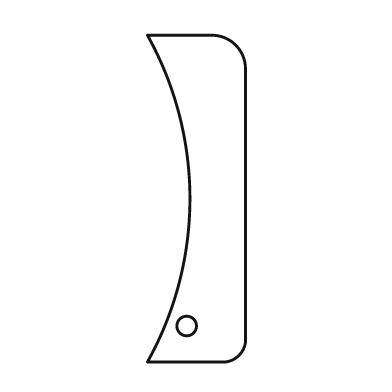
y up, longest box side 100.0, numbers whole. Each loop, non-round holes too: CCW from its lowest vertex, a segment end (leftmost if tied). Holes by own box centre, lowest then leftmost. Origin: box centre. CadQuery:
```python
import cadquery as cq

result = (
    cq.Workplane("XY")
    .moveTo(-15.0, -50.0)
    .lineTo(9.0, -50.0)
    .threePointArc((13.0, -48.0), (15.0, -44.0))
    .lineTo(15.0, 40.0)
    .threePointArc((12.0, 47.0), (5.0, 50.0))
    .lineTo(-15.0, 50.0)
    .threePointArc((-2.0, 0.0), (-15.0, -50.0))
    .close()
    .moveTo(-3.0, -39.0)
    .circle(3.0)
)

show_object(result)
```